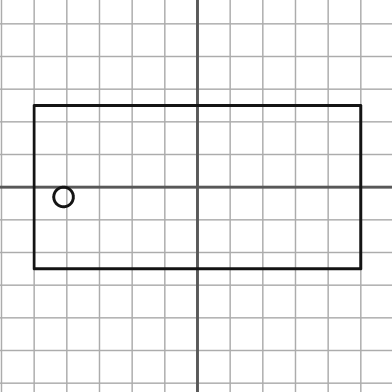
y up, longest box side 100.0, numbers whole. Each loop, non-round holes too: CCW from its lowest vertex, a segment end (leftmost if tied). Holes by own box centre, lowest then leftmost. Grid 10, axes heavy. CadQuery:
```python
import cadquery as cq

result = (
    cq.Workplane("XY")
    .moveTo(-50.0, -25.0)
    .lineTo(50.0, -25.0)
    .lineTo(50.0, 25.0)
    .lineTo(-50.0, 25.0)
    .close()
    .moveTo(-41.0, -3.0)
    .circle(3.0)
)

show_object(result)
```